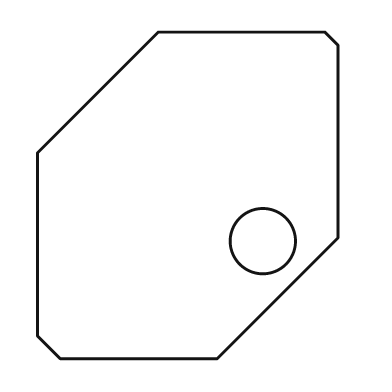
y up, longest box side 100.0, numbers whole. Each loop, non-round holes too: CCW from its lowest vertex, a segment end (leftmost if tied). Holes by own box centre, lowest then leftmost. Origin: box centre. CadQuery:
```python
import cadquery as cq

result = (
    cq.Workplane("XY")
    .moveTo(-39.0, -50.0)
    .lineTo(9.0, -50.0)
    .lineTo(46.0, -13.0)
    .lineTo(46.0, 46.0)
    .lineTo(42.0, 50.0)
    .lineTo(-9.0, 50.0)
    .lineTo(-46.0, 13.0)
    .lineTo(-46.0, -43.0)
    .close()
    .moveTo(23.0, -14.0)
    .circle(10.0)
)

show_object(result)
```